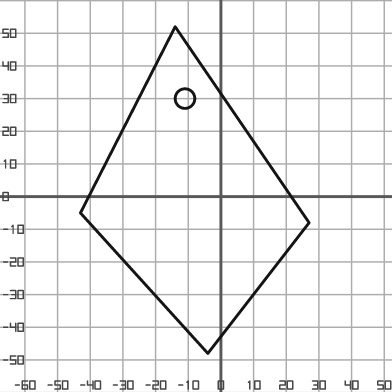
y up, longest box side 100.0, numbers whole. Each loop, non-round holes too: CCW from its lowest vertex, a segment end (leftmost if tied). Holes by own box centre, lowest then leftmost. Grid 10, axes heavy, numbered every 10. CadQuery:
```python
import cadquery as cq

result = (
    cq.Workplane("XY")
    .moveTo(-4.0, -48.0)
    .lineTo(27.0, -8.0)
    .lineTo(-14.0, 52.0)
    .lineTo(-43.0, -5.0)
    .close()
    .moveTo(-11.0, 30.0)
    .circle(3.0)
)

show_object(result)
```